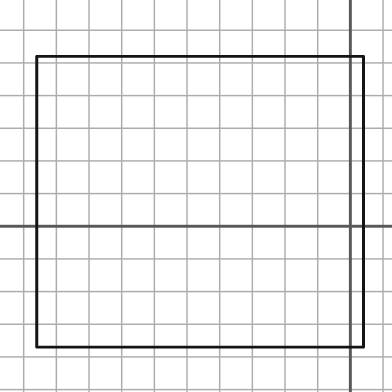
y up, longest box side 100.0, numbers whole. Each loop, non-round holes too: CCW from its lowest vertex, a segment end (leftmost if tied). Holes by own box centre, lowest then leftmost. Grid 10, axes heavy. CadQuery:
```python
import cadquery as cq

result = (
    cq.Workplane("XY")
    .moveTo(-96.0, -37.0)
    .lineTo(4.0, -37.0)
    .lineTo(4.0, 52.0)
    .lineTo(-96.0, 52.0)
    .close()
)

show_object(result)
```